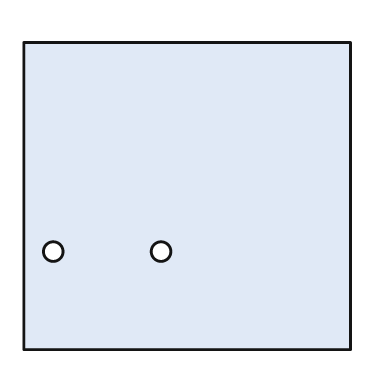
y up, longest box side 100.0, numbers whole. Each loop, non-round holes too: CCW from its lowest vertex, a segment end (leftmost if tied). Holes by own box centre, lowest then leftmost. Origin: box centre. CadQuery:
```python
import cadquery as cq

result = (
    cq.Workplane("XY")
    .moveTo(-50.0, -47.0)
    .lineTo(50.0, -47.0)
    .lineTo(50.0, 47.0)
    .lineTo(-50.0, 47.0)
    .close()
    .moveTo(-41.0, -17.0)
    .circle(3.0)
    .moveTo(-8.0, -17.0)
    .circle(3.0)
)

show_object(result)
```